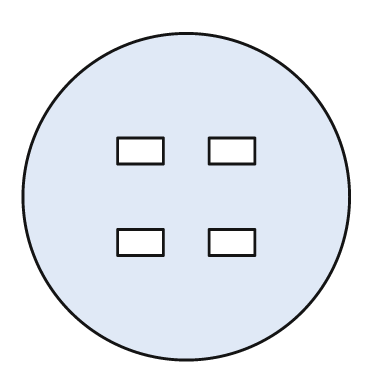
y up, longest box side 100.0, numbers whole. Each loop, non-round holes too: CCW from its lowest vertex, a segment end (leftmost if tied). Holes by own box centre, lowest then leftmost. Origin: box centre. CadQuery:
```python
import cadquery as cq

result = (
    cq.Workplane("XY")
    .moveTo(0.0, 0.0)
    .circle(50.0)
    .moveTo(-21.0, -18.0)
    .lineTo(-7.0, -18.0)
    .lineTo(-7.0, -10.0)
    .lineTo(-21.0, -10.0)
    .close()
    .moveTo(7.0, -18.0)
    .lineTo(21.0, -18.0)
    .lineTo(21.0, -10.0)
    .lineTo(7.0, -10.0)
    .close()
    .moveTo(-21.0, 10.0)
    .lineTo(-7.0, 10.0)
    .lineTo(-7.0, 18.0)
    .lineTo(-21.0, 18.0)
    .close()
    .moveTo(7.0, 10.0)
    .lineTo(21.0, 10.0)
    .lineTo(21.0, 18.0)
    .lineTo(7.0, 18.0)
    .close()
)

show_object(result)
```